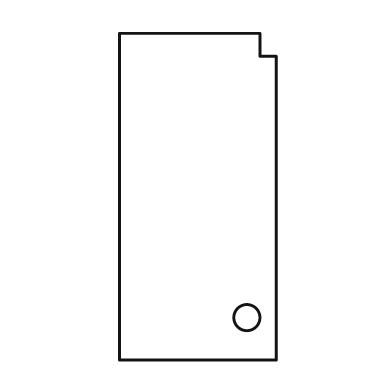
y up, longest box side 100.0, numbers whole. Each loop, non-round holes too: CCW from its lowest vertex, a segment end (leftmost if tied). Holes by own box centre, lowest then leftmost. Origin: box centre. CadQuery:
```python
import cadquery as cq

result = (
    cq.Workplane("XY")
    .moveTo(-24.0, -50.0)
    .lineTo(24.0, -50.0)
    .lineTo(24.0, 43.0)
    .lineTo(19.0, 43.0)
    .lineTo(19.0, 50.0)
    .lineTo(-24.0, 50.0)
    .close()
    .moveTo(15.0, -37.0)
    .circle(4.0)
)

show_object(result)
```